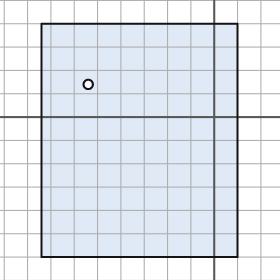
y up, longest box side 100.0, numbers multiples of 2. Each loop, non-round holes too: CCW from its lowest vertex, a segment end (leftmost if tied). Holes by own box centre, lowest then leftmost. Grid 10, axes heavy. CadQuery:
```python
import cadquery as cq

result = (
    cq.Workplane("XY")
    .moveTo(-74.0, -60.0)
    .lineTo(10.0, -60.0)
    .lineTo(10.0, 40.0)
    .lineTo(-74.0, 40.0)
    .close()
    .moveTo(-54.0, 14.0)
    .circle(2.0)
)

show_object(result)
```